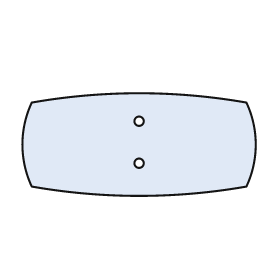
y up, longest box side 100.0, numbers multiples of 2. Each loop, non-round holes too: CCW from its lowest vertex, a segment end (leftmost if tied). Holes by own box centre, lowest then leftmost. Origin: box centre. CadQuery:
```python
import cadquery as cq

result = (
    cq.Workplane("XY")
    .moveTo(-46.0, -18.0)
    .threePointArc((0.0, -22.0), (46.0, -18.0))
    .threePointArc((50.0, 0.0), (46.0, 18.0))
    .threePointArc((0.0, 22.0), (-46.0, 18.0))
    .threePointArc((-50.0, 0.0), (-46.0, -18.0))
    .close()
    .moveTo(0.0, -8.0)
    .circle(2.0)
    .moveTo(0.0, 10.0)
    .circle(2.0)
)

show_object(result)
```